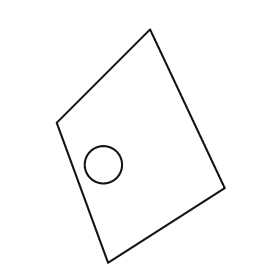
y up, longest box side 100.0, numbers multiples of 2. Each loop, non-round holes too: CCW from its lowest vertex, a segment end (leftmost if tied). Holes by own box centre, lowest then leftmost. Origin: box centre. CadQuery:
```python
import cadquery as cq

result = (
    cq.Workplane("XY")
    .moveTo(-14.0, -50.0)
    .lineTo(36.0, -18.0)
    .lineTo(4.0, 50.0)
    .lineTo(-36.0, 10.0)
    .close()
    .moveTo(-16.0, -8.0)
    .circle(8.0)
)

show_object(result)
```